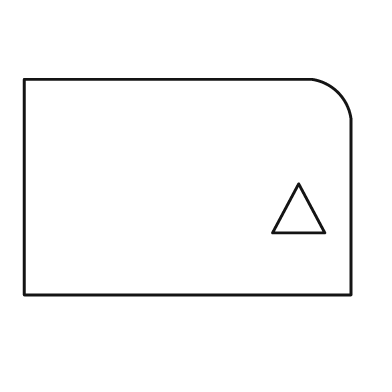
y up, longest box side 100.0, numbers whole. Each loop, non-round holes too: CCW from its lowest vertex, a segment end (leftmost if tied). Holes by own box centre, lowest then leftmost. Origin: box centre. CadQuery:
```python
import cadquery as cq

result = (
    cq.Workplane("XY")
    .moveTo(-50.0, -33.0)
    .lineTo(50.0, -33.0)
    .lineTo(50.0, 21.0)
    .threePointArc((46.0, 29.0), (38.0, 33.0))
    .lineTo(-50.0, 33.0)
    .close()
    .moveTo(26.0, -14.0)
    .lineTo(42.0, -14.0)
    .lineTo(34.0, 1.0)
    .close()
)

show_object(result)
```